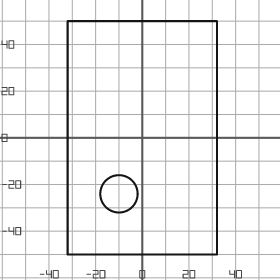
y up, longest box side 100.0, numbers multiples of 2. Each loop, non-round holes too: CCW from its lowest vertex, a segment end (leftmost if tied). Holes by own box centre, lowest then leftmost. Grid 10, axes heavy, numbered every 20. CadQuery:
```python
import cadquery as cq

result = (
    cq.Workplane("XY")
    .moveTo(-32.0, -50.0)
    .lineTo(32.0, -50.0)
    .lineTo(32.0, 50.0)
    .lineTo(-32.0, 50.0)
    .close()
    .moveTo(-10.0, -24.0)
    .circle(8.0)
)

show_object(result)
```